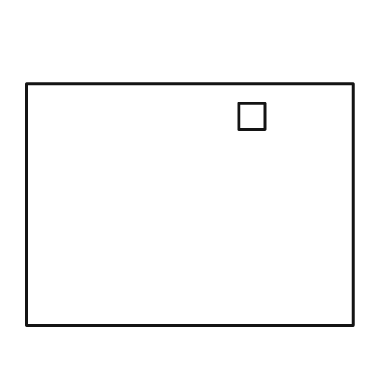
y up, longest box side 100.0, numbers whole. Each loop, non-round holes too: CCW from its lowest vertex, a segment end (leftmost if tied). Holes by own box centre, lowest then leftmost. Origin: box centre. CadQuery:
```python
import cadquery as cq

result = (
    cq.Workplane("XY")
    .moveTo(-50.0, -37.0)
    .lineTo(50.0, -37.0)
    .lineTo(50.0, 37.0)
    .lineTo(-50.0, 37.0)
    .close()
    .moveTo(15.0, 23.0)
    .lineTo(23.0, 23.0)
    .lineTo(23.0, 31.0)
    .lineTo(15.0, 31.0)
    .close()
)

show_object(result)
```